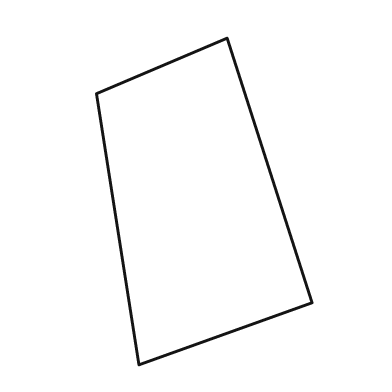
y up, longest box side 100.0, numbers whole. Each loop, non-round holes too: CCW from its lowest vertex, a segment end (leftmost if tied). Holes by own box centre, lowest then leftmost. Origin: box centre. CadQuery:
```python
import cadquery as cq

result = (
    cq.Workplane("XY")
    .moveTo(-20.0, -50.0)
    .lineTo(33.0, -31.0)
    .lineTo(7.0, 50.0)
    .lineTo(-33.0, 33.0)
    .close()
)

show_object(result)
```